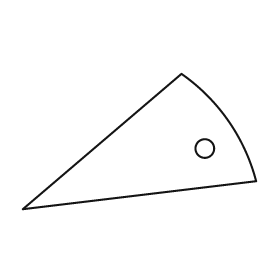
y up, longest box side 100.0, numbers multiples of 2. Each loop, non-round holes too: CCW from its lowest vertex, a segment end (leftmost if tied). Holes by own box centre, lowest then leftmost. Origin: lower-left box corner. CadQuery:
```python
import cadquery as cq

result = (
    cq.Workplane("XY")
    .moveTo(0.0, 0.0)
    .lineTo(100.0, 12.0)
    .threePointArc((88.0, 38.0), (68.0, 58.0))
    .close()
    .moveTo(78.0, 26.0)
    .circle(4.0)
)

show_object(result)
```